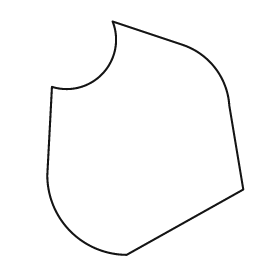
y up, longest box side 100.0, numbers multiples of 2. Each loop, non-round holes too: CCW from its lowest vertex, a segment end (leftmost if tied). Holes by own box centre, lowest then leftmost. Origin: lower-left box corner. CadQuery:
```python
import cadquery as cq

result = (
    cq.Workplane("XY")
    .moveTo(34.0, 0.0)
    .lineTo(84.0, 28.0)
    .lineTo(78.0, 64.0)
    .threePointArc((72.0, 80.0), (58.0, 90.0))
    .lineTo(28.0, 100.0)
    .threePointArc((24.0, 78.0), (2.0, 72.0))
    .lineTo(0.0, 34.0)
    .threePointArc((10.0, 10.0), (34.0, 0.0))
    .close()
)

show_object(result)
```